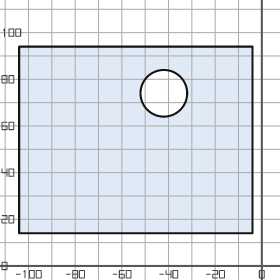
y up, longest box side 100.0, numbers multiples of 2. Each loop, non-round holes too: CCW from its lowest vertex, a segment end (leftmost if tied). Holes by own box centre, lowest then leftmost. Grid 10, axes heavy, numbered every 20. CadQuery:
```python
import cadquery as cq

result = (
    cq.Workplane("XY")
    .moveTo(-104.0, 14.0)
    .lineTo(-4.0, 14.0)
    .lineTo(-4.0, 94.0)
    .lineTo(-104.0, 94.0)
    .close()
    .moveTo(-42.0, 74.0)
    .circle(10.0)
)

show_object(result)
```